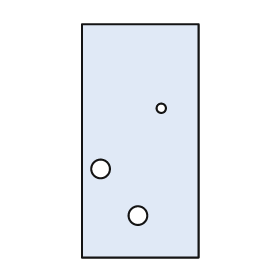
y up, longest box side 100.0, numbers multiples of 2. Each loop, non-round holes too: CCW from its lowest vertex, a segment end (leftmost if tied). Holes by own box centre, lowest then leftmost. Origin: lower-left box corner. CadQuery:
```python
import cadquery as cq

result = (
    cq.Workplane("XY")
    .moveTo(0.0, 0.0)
    .lineTo(50.0, 0.0)
    .lineTo(50.0, 100.0)
    .lineTo(0.0, 100.0)
    .close()
    .moveTo(24.0, 18.0)
    .circle(4.0)
    .moveTo(8.0, 38.0)
    .circle(4.0)
    .moveTo(34.0, 64.0)
    .circle(2.0)
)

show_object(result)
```